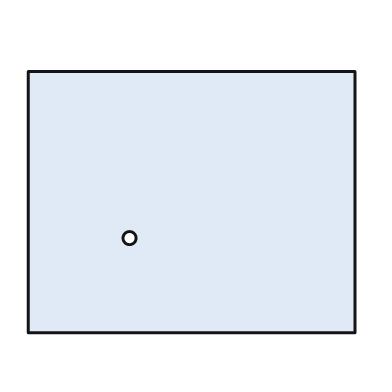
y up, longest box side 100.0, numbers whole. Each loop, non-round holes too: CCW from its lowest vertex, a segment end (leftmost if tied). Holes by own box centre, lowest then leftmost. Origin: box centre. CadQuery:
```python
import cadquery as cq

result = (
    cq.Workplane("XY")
    .moveTo(-50.0, -40.0)
    .lineTo(50.0, -40.0)
    .lineTo(50.0, 40.0)
    .lineTo(-50.0, 40.0)
    .close()
    .moveTo(-19.0, -11.0)
    .circle(2.0)
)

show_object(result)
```